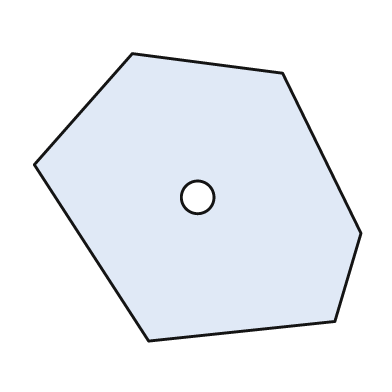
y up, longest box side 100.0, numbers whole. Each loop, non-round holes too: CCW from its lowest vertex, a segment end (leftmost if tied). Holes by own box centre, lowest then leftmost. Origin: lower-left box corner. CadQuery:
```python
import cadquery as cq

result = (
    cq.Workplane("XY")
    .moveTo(35.0, 0.0)
    .lineTo(92.0, 6.0)
    .lineTo(100.0, 33.0)
    .lineTo(76.0, 82.0)
    .lineTo(30.0, 88.0)
    .lineTo(0.0, 54.0)
    .close()
    .moveTo(50.0, 44.0)
    .circle(5.0)
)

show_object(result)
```